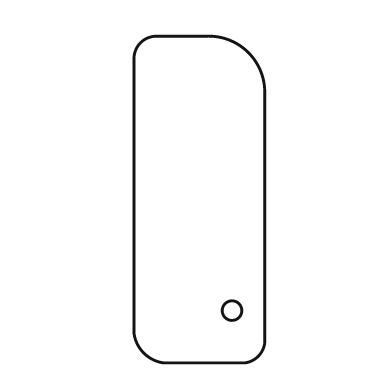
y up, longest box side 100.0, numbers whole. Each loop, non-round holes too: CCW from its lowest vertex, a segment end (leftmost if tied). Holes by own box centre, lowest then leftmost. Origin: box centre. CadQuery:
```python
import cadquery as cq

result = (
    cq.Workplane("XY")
    .moveTo(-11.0, -50.0)
    .lineTo(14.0, -50.0)
    .threePointArc((18.0, -48.0), (20.0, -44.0))
    .lineTo(20.0, 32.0)
    .threePointArc((15.0, 45.0), (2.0, 50.0))
    .lineTo(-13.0, 50.0)
    .threePointArc((-18.0, 48.0), (-20.0, 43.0))
    .lineTo(-20.0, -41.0)
    .threePointArc((-17.0, -47.0), (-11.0, -50.0))
    .close()
    .moveTo(10.0, -34.0)
    .circle(3.0)
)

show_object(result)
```